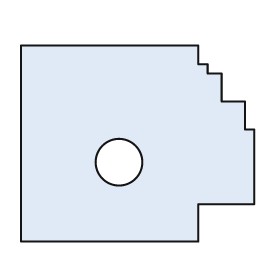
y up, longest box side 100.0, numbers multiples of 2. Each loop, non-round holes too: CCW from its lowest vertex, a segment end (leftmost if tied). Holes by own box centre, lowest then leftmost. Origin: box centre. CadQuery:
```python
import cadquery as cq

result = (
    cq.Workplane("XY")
    .moveTo(-50.0, -42.0)
    .lineTo(26.0, -42.0)
    .lineTo(26.0, -26.0)
    .lineTo(50.0, -26.0)
    .lineTo(50.0, 6.0)
    .lineTo(46.0, 6.0)
    .lineTo(46.0, 18.0)
    .lineTo(36.0, 18.0)
    .lineTo(36.0, 30.0)
    .lineTo(30.0, 30.0)
    .lineTo(30.0, 34.0)
    .lineTo(26.0, 34.0)
    .lineTo(26.0, 42.0)
    .lineTo(-50.0, 42.0)
    .close()
    .moveTo(-8.0, -8.0)
    .circle(10.0)
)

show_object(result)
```